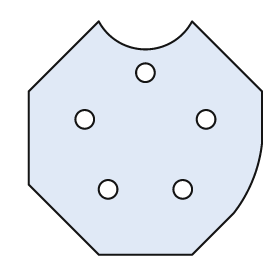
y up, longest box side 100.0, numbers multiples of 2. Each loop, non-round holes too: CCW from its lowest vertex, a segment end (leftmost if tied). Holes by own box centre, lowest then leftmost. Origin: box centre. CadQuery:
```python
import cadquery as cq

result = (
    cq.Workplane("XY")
    .moveTo(-20.0, -50.0)
    .lineTo(20.0, -50.0)
    .lineTo(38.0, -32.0)
    .threePointArc((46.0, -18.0), (50.0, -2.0))
    .lineTo(50.0, 20.0)
    .lineTo(20.0, 50.0)
    .threePointArc((0.0, 38.0), (-20.0, 50.0))
    .lineTo(-50.0, 20.0)
    .lineTo(-50.0, -20.0)
    .close()
    .moveTo(-16.0, -22.0)
    .circle(4.0)
    .moveTo(16.0, -22.0)
    .circle(4.0)
    .moveTo(-26.0, 8.0)
    .circle(4.0)
    .moveTo(26.0, 8.0)
    .circle(4.0)
    .moveTo(0.0, 28.0)
    .circle(4.0)
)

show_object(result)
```